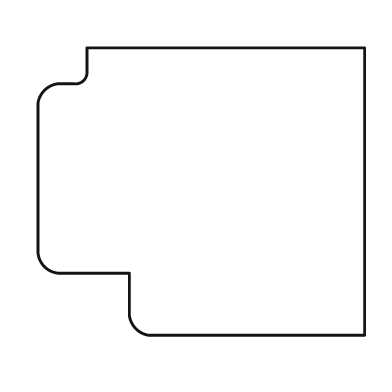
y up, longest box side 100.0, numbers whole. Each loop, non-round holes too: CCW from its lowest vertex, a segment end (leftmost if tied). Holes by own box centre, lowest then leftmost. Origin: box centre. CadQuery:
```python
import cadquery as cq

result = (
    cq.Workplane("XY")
    .moveTo(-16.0, -44.0)
    .lineTo(50.0, -44.0)
    .lineTo(50.0, 44.0)
    .lineTo(-35.0, 44.0)
    .lineTo(-35.0, 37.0)
    .threePointArc((-36.0, 34.0), (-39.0, 33.0))
    .lineTo(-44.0, 33.0)
    .threePointArc((-48.0, 31.0), (-50.0, 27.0))
    .lineTo(-50.0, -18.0)
    .threePointArc((-48.0, -23.0), (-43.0, -25.0))
    .lineTo(-22.0, -25.0)
    .lineTo(-22.0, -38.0)
    .threePointArc((-20.0, -42.0), (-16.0, -44.0))
    .close()
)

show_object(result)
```